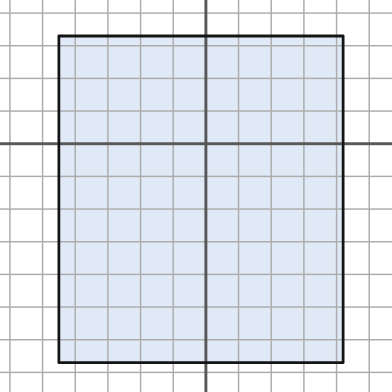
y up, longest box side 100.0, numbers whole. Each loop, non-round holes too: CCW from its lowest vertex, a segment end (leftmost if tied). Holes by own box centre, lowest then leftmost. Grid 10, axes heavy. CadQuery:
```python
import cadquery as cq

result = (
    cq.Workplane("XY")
    .moveTo(-45.0, -67.0)
    .lineTo(42.0, -67.0)
    .lineTo(42.0, 33.0)
    .lineTo(-45.0, 33.0)
    .close()
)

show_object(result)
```